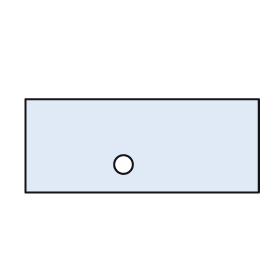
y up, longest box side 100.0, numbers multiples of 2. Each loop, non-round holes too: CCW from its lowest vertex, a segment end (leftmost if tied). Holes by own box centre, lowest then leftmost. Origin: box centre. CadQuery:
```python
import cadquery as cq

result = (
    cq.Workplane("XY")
    .moveTo(-50.0, -20.0)
    .lineTo(50.0, -20.0)
    .lineTo(50.0, 20.0)
    .lineTo(-50.0, 20.0)
    .close()
    .moveTo(-8.0, -8.0)
    .circle(4.0)
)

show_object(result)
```